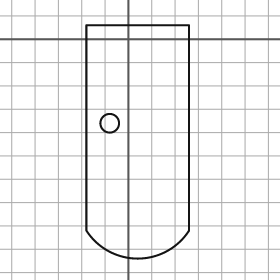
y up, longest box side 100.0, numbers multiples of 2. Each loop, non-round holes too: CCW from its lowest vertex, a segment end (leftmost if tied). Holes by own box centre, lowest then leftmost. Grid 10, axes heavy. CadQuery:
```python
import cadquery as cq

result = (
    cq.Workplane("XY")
    .moveTo(-18.0, -82.0)
    .threePointArc((4.0, -94.0), (26.0, -82.0))
    .lineTo(26.0, 6.0)
    .lineTo(-18.0, 6.0)
    .close()
    .moveTo(-8.0, -36.0)
    .circle(4.0)
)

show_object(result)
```